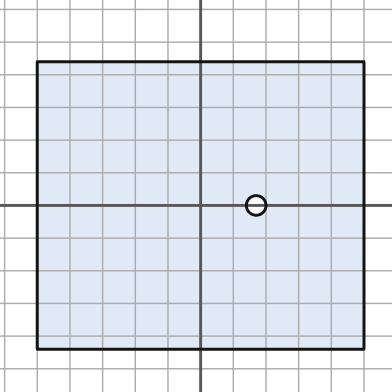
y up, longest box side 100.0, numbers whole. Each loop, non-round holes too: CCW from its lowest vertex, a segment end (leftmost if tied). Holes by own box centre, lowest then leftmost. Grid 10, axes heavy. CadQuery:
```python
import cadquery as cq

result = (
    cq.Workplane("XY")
    .moveTo(-50.0, -44.0)
    .lineTo(50.0, -44.0)
    .lineTo(50.0, 44.0)
    .lineTo(-50.0, 44.0)
    .close()
    .moveTo(17.0, 0.0)
    .circle(3.0)
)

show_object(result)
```